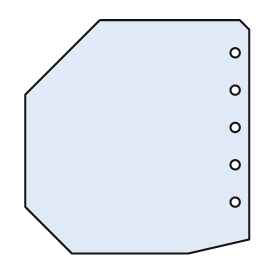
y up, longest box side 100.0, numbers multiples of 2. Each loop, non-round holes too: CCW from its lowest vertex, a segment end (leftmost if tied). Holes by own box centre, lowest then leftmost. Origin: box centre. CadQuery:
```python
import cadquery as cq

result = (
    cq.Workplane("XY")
    .moveTo(-28.0, -50.0)
    .lineTo(22.0, -50.0)
    .lineTo(48.0, -44.0)
    .lineTo(48.0, 46.0)
    .lineTo(44.0, 50.0)
    .lineTo(-16.0, 50.0)
    .lineTo(-48.0, 18.0)
    .lineTo(-48.0, -30.0)
    .close()
    .moveTo(42.0, -28.0)
    .circle(2.0)
    .moveTo(42.0, -12.0)
    .circle(2.0)
    .moveTo(42.0, 4.0)
    .circle(2.0)
    .moveTo(42.0, 20.0)
    .circle(2.0)
    .moveTo(42.0, 36.0)
    .circle(2.0)
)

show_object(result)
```